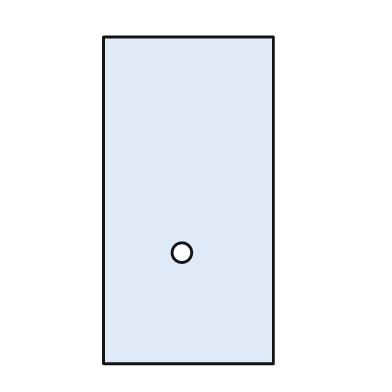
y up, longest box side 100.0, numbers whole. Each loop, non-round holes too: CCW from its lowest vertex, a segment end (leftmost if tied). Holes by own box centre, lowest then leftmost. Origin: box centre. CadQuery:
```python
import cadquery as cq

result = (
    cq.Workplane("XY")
    .moveTo(-26.0, -50.0)
    .lineTo(26.0, -50.0)
    .lineTo(26.0, 50.0)
    .lineTo(-26.0, 50.0)
    .close()
    .moveTo(-2.0, -16.0)
    .circle(3.0)
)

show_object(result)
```